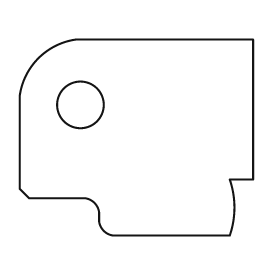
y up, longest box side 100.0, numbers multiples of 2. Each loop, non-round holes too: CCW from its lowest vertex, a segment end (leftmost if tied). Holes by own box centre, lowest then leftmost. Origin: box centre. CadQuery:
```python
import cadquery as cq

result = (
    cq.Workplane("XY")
    .moveTo(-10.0, -42.0)
    .lineTo(40.0, -42.0)
    .threePointArc((42.0, -30.0), (40.0, -18.0))
    .lineTo(50.0, -18.0)
    .lineTo(50.0, 42.0)
    .lineTo(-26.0, 42.0)
    .threePointArc((-42.0, 34.0), (-50.0, 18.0))
    .lineTo(-50.0, -22.0)
    .lineTo(-46.0, -26.0)
    .lineTo(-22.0, -26.0)
    .threePointArc((-18.0, -28.0), (-16.0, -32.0))
    .lineTo(-16.0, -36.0)
    .threePointArc((-14.0, -40.0), (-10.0, -42.0))
    .close()
    .moveTo(-24.0, 14.0)
    .circle(10.0)
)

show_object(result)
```